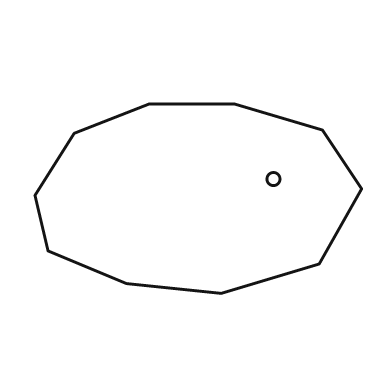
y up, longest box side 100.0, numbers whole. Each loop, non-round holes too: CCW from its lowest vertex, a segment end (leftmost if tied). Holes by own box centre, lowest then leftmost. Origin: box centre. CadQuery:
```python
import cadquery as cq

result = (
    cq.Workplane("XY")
    .moveTo(7.0, -29.0)
    .lineTo(37.0, -20.0)
    .lineTo(50.0, 3.0)
    .lineTo(38.0, 21.0)
    .lineTo(11.0, 29.0)
    .lineTo(-15.0, 29.0)
    .lineTo(-38.0, 20.0)
    .lineTo(-50.0, 1.0)
    .lineTo(-46.0, -16.0)
    .lineTo(-22.0, -26.0)
    .close()
    .moveTo(23.0, 6.0)
    .circle(2.0)
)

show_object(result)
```